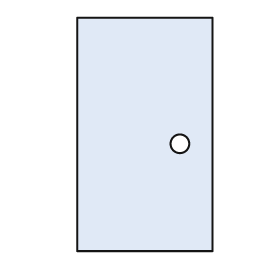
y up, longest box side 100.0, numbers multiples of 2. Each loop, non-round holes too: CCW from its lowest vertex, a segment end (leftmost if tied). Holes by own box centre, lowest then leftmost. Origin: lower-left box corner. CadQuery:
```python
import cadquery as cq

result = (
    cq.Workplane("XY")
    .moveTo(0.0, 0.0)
    .lineTo(58.0, 0.0)
    .lineTo(58.0, 100.0)
    .lineTo(0.0, 100.0)
    .close()
    .moveTo(44.0, 46.0)
    .circle(4.0)
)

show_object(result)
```